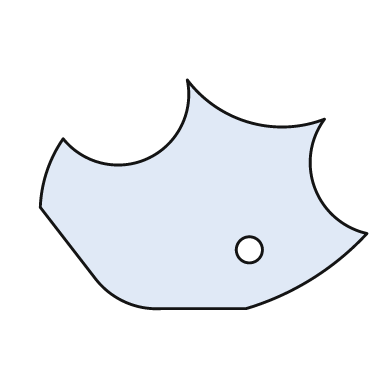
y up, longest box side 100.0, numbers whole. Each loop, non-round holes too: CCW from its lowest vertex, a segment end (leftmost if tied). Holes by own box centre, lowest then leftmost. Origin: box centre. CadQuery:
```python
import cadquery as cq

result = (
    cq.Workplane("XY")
    .moveTo(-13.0, -35.0)
    .lineTo(13.0, -35.0)
    .threePointArc((33.0, -26.0), (50.0, -12.0))
    .threePointArc((34.0, 2.0), (37.0, 23.0))
    .threePointArc((14.0, 22.0), (-5.0, 35.0))
    .threePointArc((-17.0, 11.0), (-43.0, 17.0))
    .threePointArc((-48.0, 7.0), (-50.0, -4.0))
    .lineTo(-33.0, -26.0)
    .threePointArc((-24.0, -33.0), (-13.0, -35.0))
    .close()
    .moveTo(14.0, -17.0)
    .circle(4.0)
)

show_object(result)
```